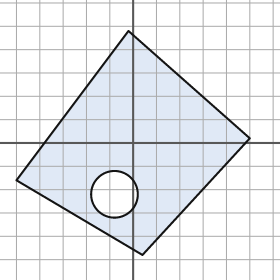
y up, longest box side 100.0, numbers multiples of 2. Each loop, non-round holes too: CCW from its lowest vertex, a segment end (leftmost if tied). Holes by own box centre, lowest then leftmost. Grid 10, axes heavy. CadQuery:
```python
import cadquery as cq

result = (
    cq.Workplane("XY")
    .moveTo(4.0, -48.0)
    .lineTo(50.0, 2.0)
    .lineTo(-2.0, 48.0)
    .lineTo(-50.0, -16.0)
    .close()
    .moveTo(-8.0, -22.0)
    .circle(10.0)
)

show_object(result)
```